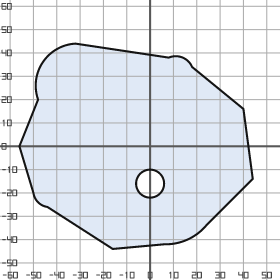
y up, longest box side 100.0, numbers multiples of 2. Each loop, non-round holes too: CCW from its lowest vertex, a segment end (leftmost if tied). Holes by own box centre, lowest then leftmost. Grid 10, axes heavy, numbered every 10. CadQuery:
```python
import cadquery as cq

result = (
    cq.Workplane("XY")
    .moveTo(-16.0, -44.0)
    .lineTo(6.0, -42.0)
    .threePointArc((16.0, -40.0), (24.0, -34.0))
    .lineTo(44.0, -14.0)
    .lineTo(40.0, 16.0)
    .lineTo(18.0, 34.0)
    .threePointArc((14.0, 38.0), (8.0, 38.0))
    .lineTo(-32.0, 44.0)
    .threePointArc((-46.0, 36.0), (-48.0, 20.0))
    .lineTo(-56.0, 0.0)
    .lineTo(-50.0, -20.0)
    .threePointArc((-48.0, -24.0), (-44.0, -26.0))
    .close()
    .moveTo(0.0, -16.0)
    .circle(6.0)
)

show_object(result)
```